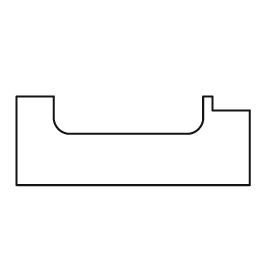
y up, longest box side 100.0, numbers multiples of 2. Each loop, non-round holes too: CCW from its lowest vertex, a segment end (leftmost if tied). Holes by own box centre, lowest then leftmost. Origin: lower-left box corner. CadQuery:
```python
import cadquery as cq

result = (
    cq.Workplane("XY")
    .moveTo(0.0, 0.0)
    .lineTo(100.0, 0.0)
    .lineTo(100.0, 32.0)
    .lineTo(84.0, 32.0)
    .lineTo(84.0, 38.0)
    .lineTo(80.0, 38.0)
    .lineTo(80.0, 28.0)
    .threePointArc((78.0, 24.0), (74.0, 22.0))
    .lineTo(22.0, 22.0)
    .threePointArc((18.0, 24.0), (16.0, 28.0))
    .lineTo(16.0, 38.0)
    .lineTo(0.0, 38.0)
    .close()
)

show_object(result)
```